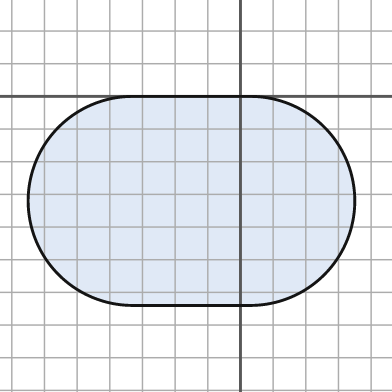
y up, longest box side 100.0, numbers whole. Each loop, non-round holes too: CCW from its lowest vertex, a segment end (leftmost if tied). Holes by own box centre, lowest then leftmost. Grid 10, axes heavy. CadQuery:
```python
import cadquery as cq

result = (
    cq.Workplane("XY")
    .moveTo(-33.0, -64.0)
    .lineTo(3.0, -64.0)
    .threePointArc((35.0, -32.0), (3.0, 0.0))
    .lineTo(-33.0, 0.0)
    .threePointArc((-65.0, -32.0), (-33.0, -64.0))
    .close()
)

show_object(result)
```